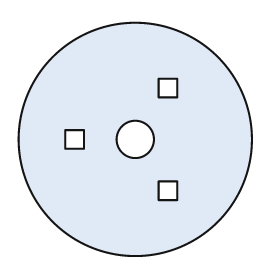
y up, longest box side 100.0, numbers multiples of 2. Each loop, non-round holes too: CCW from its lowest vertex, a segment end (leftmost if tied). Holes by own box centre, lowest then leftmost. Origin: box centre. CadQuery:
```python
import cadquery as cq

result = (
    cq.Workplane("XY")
    .moveTo(0.0, 0.0)
    .circle(50.0)
    .moveTo(10.0, -26.0)
    .lineTo(18.0, -26.0)
    .lineTo(18.0, -18.0)
    .lineTo(10.0, -18.0)
    .close()
    .moveTo(-30.0, -4.0)
    .lineTo(-22.0, -4.0)
    .lineTo(-22.0, 4.0)
    .lineTo(-30.0, 4.0)
    .close()
    .moveTo(0.0, 0.0)
    .circle(8.0)
    .moveTo(10.0, 18.0)
    .lineTo(18.0, 18.0)
    .lineTo(18.0, 26.0)
    .lineTo(10.0, 26.0)
    .close()
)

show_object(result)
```